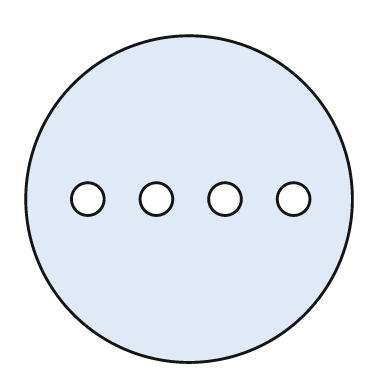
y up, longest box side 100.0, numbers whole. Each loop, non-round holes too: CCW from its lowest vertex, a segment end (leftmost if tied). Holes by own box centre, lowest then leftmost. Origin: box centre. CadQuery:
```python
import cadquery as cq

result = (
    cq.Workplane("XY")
    .moveTo(0.0, 0.0)
    .circle(50.0)
    .moveTo(-31.0, 0.0)
    .circle(5.0)
    .moveTo(-10.0, 0.0)
    .circle(5.0)
    .moveTo(11.0, 0.0)
    .circle(5.0)
    .moveTo(32.0, 0.0)
    .circle(5.0)
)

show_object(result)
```